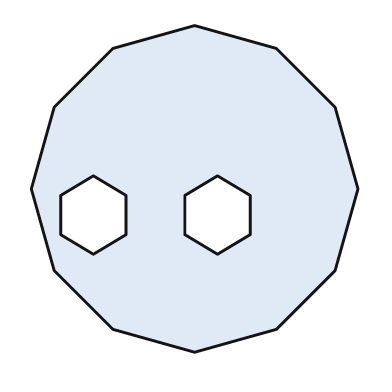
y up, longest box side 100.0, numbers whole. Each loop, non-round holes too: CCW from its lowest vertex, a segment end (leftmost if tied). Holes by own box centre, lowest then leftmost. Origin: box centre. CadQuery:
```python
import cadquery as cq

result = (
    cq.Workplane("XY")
    .moveTo(0.0, -50.0)
    .lineTo(25.0, -43.0)
    .lineTo(43.0, -25.0)
    .lineTo(50.0, 0.0)
    .lineTo(43.0, 25.0)
    .lineTo(25.0, 43.0)
    .lineTo(0.0, 50.0)
    .lineTo(-25.0, 43.0)
    .lineTo(-43.0, 25.0)
    .lineTo(-50.0, 0.0)
    .lineTo(-43.0, -25.0)
    .lineTo(-25.0, -43.0)
    .close()
    .moveTo(-31.0, -20.0)
    .lineTo(-21.0, -14.0)
    .lineTo(-21.0, -2.0)
    .lineTo(-31.0, 4.0)
    .lineTo(-41.0, -2.0)
    .lineTo(-41.0, -14.0)
    .close()
    .moveTo(7.0, -20.0)
    .lineTo(17.0, -14.0)
    .lineTo(17.0, -2.0)
    .lineTo(7.0, 4.0)
    .lineTo(-3.0, -2.0)
    .lineTo(-3.0, -14.0)
    .close()
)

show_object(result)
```